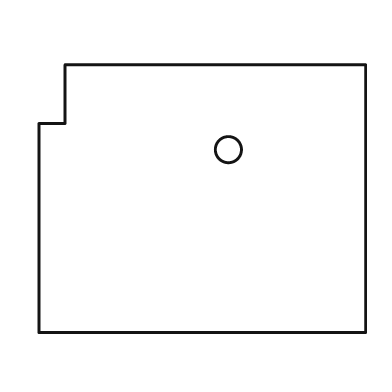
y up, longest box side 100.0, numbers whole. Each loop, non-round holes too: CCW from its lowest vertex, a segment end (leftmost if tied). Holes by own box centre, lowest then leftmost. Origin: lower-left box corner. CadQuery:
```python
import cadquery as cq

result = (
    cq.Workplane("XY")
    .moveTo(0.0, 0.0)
    .lineTo(100.0, 0.0)
    .lineTo(100.0, 82.0)
    .lineTo(8.0, 82.0)
    .lineTo(8.0, 64.0)
    .lineTo(0.0, 64.0)
    .close()
    .moveTo(58.0, 56.0)
    .circle(4.0)
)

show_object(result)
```